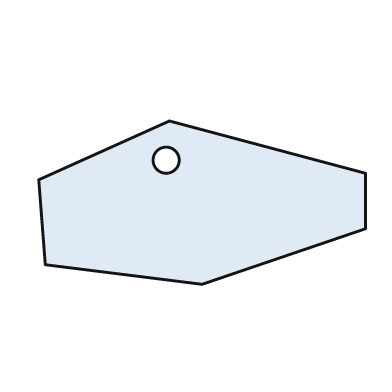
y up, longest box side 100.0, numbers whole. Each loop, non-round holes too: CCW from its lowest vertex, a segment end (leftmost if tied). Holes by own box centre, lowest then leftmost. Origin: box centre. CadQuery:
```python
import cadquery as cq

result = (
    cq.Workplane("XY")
    .moveTo(0.0, -25.0)
    .lineTo(50.0, -8.0)
    .lineTo(50.0, 9.0)
    .lineTo(-10.0, 25.0)
    .lineTo(-50.0, 7.0)
    .lineTo(-48.0, -19.0)
    .close()
    .moveTo(-11.0, 13.0)
    .circle(4.0)
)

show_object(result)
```